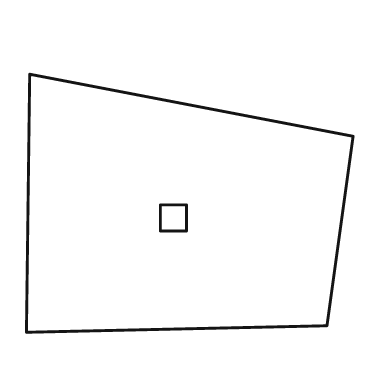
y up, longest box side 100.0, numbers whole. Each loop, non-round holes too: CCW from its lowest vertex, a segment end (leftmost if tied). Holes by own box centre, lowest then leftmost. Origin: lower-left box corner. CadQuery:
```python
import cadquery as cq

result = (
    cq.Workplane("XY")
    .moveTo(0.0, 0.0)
    .lineTo(92.0, 2.0)
    .lineTo(100.0, 60.0)
    .lineTo(1.0, 79.0)
    .close()
    .moveTo(41.0, 31.0)
    .lineTo(49.0, 31.0)
    .lineTo(49.0, 39.0)
    .lineTo(41.0, 39.0)
    .close()
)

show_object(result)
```